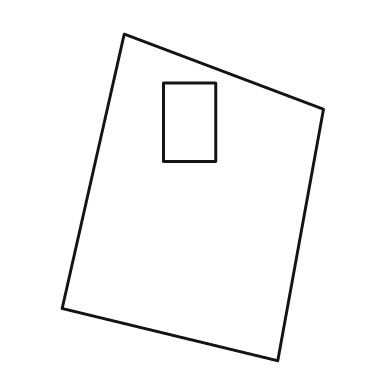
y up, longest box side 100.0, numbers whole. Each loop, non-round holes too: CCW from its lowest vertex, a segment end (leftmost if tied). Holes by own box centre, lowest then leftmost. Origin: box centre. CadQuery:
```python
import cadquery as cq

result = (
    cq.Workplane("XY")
    .moveTo(26.0, -50.0)
    .lineTo(40.0, 27.0)
    .lineTo(-21.0, 50.0)
    .lineTo(-40.0, -34.0)
    .close()
    .moveTo(-9.0, 11.0)
    .lineTo(7.0, 11.0)
    .lineTo(7.0, 35.0)
    .lineTo(-9.0, 35.0)
    .close()
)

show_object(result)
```